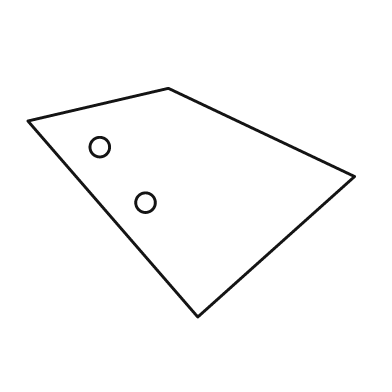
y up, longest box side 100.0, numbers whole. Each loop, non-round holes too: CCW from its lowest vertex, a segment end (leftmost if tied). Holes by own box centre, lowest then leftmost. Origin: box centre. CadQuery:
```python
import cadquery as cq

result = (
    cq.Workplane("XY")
    .moveTo(2.0, -35.0)
    .lineTo(50.0, 8.0)
    .lineTo(-7.0, 35.0)
    .lineTo(-50.0, 25.0)
    .close()
    .moveTo(-14.0, 0.0)
    .circle(3.0)
    .moveTo(-28.0, 17.0)
    .circle(3.0)
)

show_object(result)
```